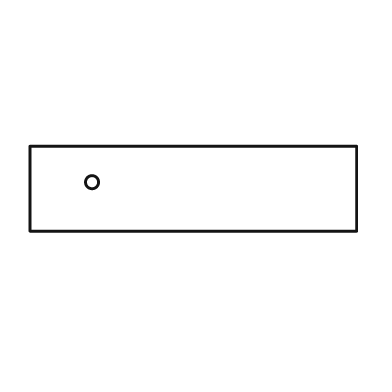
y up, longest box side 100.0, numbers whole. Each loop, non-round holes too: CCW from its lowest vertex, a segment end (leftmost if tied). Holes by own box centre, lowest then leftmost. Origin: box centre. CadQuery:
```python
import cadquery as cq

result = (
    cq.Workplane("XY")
    .moveTo(-50.0, -13.0)
    .lineTo(50.0, -13.0)
    .lineTo(50.0, 13.0)
    .lineTo(-50.0, 13.0)
    .close()
    .moveTo(-31.0, 2.0)
    .circle(2.0)
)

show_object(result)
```